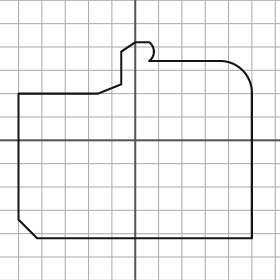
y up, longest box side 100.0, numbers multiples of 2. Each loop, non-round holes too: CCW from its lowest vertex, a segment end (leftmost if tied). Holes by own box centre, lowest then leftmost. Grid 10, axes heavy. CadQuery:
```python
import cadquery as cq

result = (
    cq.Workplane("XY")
    .moveTo(-42.0, -42.0)
    .lineTo(50.0, -42.0)
    .lineTo(50.0, 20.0)
    .threePointArc((46.0, 30.0), (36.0, 34.0))
    .lineTo(6.0, 34.0)
    .threePointArc((8.0, 38.0), (6.0, 42.0))
    .lineTo(0.0, 42.0)
    .lineTo(-6.0, 38.0)
    .lineTo(-6.0, 24.0)
    .lineTo(-16.0, 20.0)
    .lineTo(-50.0, 20.0)
    .lineTo(-50.0, -34.0)
    .close()
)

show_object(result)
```